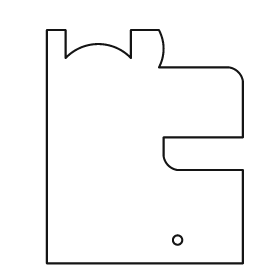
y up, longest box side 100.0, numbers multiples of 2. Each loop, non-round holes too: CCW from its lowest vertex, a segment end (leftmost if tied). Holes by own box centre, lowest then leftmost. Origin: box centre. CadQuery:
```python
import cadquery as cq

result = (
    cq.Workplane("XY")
    .moveTo(-42.0, -50.0)
    .lineTo(42.0, -50.0)
    .lineTo(42.0, -10.0)
    .lineTo(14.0, -10.0)
    .threePointArc((10.0, -8.0), (8.0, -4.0))
    .lineTo(8.0, 4.0)
    .lineTo(42.0, 4.0)
    .lineTo(42.0, 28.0)
    .threePointArc((40.0, 32.0), (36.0, 34.0))
    .lineTo(6.0, 34.0)
    .threePointArc((8.0, 42.0), (6.0, 50.0))
    .lineTo(-6.0, 50.0)
    .lineTo(-6.0, 38.0)
    .threePointArc((-20.0, 44.0), (-34.0, 38.0))
    .lineTo(-34.0, 50.0)
    .lineTo(-42.0, 50.0)
    .close()
    .moveTo(14.0, -40.0)
    .circle(2.0)
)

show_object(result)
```